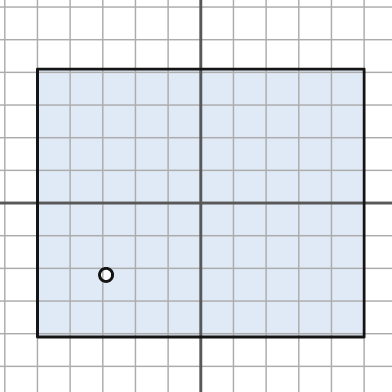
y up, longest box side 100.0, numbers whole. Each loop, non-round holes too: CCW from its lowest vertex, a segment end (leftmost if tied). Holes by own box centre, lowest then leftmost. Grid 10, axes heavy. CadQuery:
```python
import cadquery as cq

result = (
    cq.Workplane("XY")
    .moveTo(-50.0, -41.0)
    .lineTo(50.0, -41.0)
    .lineTo(50.0, 41.0)
    .lineTo(-50.0, 41.0)
    .close()
    .moveTo(-29.0, -22.0)
    .circle(2.0)
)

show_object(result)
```